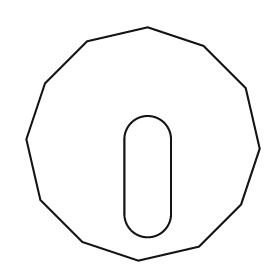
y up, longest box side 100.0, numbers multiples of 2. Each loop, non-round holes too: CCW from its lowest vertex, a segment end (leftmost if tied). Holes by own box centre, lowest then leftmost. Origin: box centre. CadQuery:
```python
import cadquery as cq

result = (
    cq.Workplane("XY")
    .moveTo(-2.0, -50.0)
    .lineTo(24.0, -44.0)
    .lineTo(42.0, -26.0)
    .lineTo(50.0, -2.0)
    .lineTo(44.0, 24.0)
    .lineTo(26.0, 42.0)
    .lineTo(2.0, 50.0)
    .lineTo(-24.0, 44.0)
    .lineTo(-42.0, 26.0)
    .lineTo(-50.0, 2.0)
    .lineTo(-44.0, -24.0)
    .lineTo(-26.0, -42.0)
    .close()
    .moveTo(-8.0, -30.0)
    .threePointArc((2.0, -40.0), (12.0, -30.0))
    .lineTo(12.0, 2.0)
    .threePointArc((2.0, 12.0), (-8.0, 2.0))
    .close()
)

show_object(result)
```